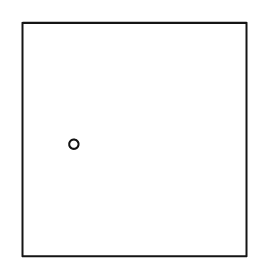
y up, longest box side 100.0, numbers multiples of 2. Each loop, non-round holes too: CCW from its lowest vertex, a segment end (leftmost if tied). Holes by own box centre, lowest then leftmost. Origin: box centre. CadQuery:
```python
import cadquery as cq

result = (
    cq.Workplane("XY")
    .moveTo(-48.0, -50.0)
    .lineTo(48.0, -50.0)
    .lineTo(48.0, 50.0)
    .lineTo(-48.0, 50.0)
    .close()
    .moveTo(-26.0, -2.0)
    .circle(2.0)
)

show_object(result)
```